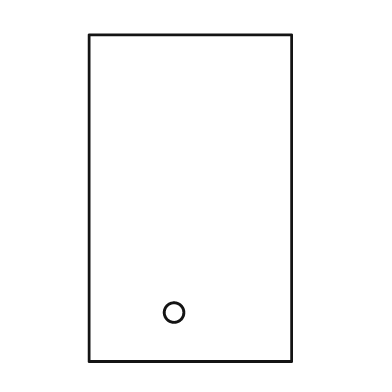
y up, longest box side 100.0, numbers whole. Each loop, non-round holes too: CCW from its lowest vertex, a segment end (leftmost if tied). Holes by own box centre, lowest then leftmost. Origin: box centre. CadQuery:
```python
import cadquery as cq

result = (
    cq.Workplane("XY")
    .moveTo(-31.0, -50.0)
    .lineTo(31.0, -50.0)
    .lineTo(31.0, 50.0)
    .lineTo(-31.0, 50.0)
    .close()
    .moveTo(-5.0, -35.0)
    .circle(3.0)
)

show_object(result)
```